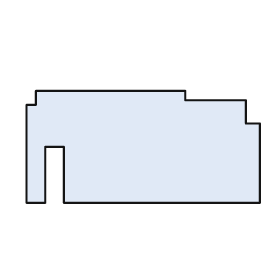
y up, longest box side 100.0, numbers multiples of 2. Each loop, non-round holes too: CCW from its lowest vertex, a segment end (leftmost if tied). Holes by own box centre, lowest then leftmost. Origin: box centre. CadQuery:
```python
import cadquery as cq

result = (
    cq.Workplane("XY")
    .moveTo(-50.0, -24.0)
    .lineTo(-42.0, -24.0)
    .lineTo(-42.0, 0.0)
    .lineTo(-34.0, 0.0)
    .lineTo(-34.0, -24.0)
    .lineTo(50.0, -24.0)
    .lineTo(50.0, 10.0)
    .lineTo(44.0, 10.0)
    .lineTo(44.0, 20.0)
    .lineTo(18.0, 20.0)
    .lineTo(18.0, 24.0)
    .lineTo(-46.0, 24.0)
    .lineTo(-46.0, 18.0)
    .lineTo(-50.0, 18.0)
    .close()
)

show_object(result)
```